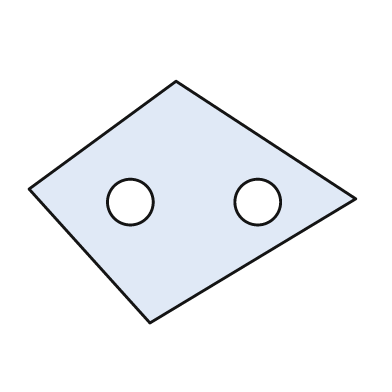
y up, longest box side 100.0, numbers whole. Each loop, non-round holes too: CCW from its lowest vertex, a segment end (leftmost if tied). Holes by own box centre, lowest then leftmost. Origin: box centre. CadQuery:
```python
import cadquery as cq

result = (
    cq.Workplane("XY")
    .moveTo(-13.0, -37.0)
    .lineTo(50.0, 1.0)
    .lineTo(-5.0, 37.0)
    .lineTo(-50.0, 4.0)
    .close()
    .moveTo(-19.0, 0.0)
    .circle(7.0)
    .moveTo(20.0, 0.0)
    .circle(7.0)
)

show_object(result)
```